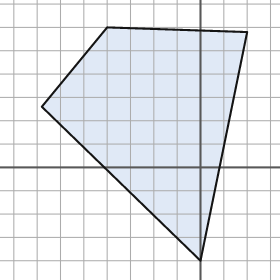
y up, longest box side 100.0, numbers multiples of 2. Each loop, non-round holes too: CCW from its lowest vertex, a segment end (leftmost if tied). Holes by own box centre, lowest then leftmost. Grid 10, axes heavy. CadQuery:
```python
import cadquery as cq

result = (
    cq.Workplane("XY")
    .moveTo(0.0, -40.0)
    .lineTo(20.0, 58.0)
    .lineTo(-40.0, 60.0)
    .lineTo(-68.0, 26.0)
    .close()
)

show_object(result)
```